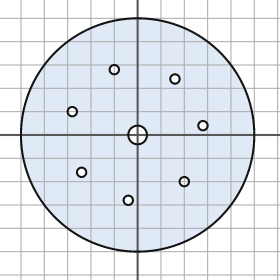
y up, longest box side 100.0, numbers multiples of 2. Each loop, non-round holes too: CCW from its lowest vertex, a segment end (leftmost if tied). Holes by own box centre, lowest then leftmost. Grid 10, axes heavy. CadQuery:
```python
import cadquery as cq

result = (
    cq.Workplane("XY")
    .moveTo(0.0, 0.0)
    .circle(50.0)
    .moveTo(-4.0, -28.0)
    .circle(2.0)
    .moveTo(20.0, -20.0)
    .circle(2.0)
    .moveTo(-24.0, -16.0)
    .circle(2.0)
    .moveTo(0.0, 0.0)
    .circle(4.0)
    .moveTo(28.0, 4.0)
    .circle(2.0)
    .moveTo(-28.0, 10.0)
    .circle(2.0)
    .moveTo(16.0, 24.0)
    .circle(2.0)
    .moveTo(-10.0, 28.0)
    .circle(2.0)
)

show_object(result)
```